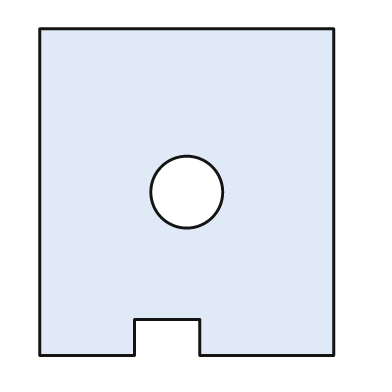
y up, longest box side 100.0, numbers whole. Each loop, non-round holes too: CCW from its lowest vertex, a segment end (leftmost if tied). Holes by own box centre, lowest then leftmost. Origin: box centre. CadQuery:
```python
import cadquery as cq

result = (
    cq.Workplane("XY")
    .moveTo(-45.0, -50.0)
    .lineTo(-16.0, -50.0)
    .lineTo(-16.0, -39.0)
    .lineTo(4.0, -39.0)
    .lineTo(4.0, -50.0)
    .lineTo(45.0, -50.0)
    .lineTo(45.0, 50.0)
    .lineTo(-45.0, 50.0)
    .close()
    .moveTo(0.0, 0.0)
    .circle(11.0)
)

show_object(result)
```